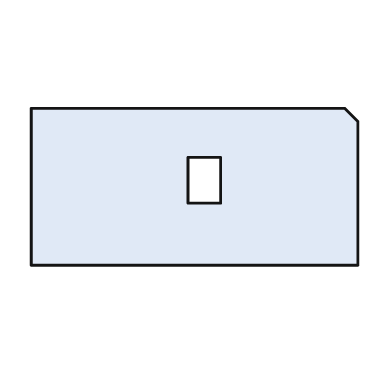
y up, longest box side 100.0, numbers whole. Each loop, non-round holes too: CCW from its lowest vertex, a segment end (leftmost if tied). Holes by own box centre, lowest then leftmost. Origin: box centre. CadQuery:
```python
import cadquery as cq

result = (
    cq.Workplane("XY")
    .moveTo(-50.0, -24.0)
    .lineTo(50.0, -24.0)
    .lineTo(50.0, 20.0)
    .lineTo(46.0, 24.0)
    .lineTo(-50.0, 24.0)
    .close()
    .moveTo(-2.0, -5.0)
    .lineTo(8.0, -5.0)
    .lineTo(8.0, 9.0)
    .lineTo(-2.0, 9.0)
    .close()
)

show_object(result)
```